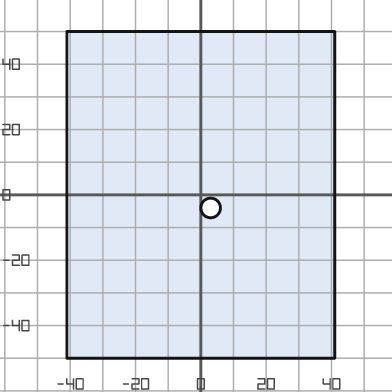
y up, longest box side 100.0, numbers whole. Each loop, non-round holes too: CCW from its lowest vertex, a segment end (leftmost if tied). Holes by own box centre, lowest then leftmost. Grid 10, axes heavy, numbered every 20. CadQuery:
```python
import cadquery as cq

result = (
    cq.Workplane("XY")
    .moveTo(-41.0, -50.0)
    .lineTo(41.0, -50.0)
    .lineTo(41.0, 50.0)
    .lineTo(-41.0, 50.0)
    .close()
    .moveTo(3.0, -4.0)
    .circle(3.0)
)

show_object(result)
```